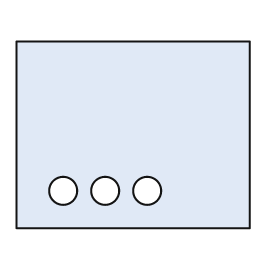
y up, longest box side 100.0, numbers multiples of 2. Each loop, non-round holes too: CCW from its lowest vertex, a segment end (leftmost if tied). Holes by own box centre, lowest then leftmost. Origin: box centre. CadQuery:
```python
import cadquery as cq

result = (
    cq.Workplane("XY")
    .moveTo(-50.0, -40.0)
    .lineTo(50.0, -40.0)
    .lineTo(50.0, 40.0)
    .lineTo(-50.0, 40.0)
    .close()
    .moveTo(-30.0, -24.0)
    .circle(6.0)
    .moveTo(-12.0, -24.0)
    .circle(6.0)
    .moveTo(6.0, -24.0)
    .circle(6.0)
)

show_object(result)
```